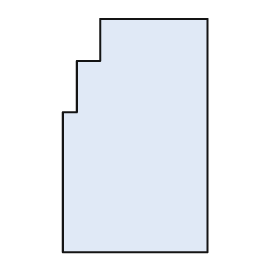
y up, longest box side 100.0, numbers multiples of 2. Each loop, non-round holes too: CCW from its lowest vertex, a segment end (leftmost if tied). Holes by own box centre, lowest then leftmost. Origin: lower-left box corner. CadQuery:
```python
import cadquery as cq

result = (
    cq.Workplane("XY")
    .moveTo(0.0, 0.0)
    .lineTo(62.0, 0.0)
    .lineTo(62.0, 100.0)
    .lineTo(16.0, 100.0)
    .lineTo(16.0, 82.0)
    .lineTo(6.0, 82.0)
    .lineTo(6.0, 60.0)
    .lineTo(0.0, 60.0)
    .close()
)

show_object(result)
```